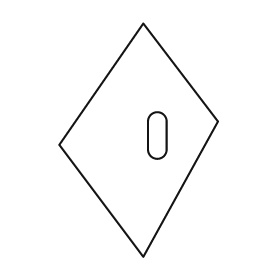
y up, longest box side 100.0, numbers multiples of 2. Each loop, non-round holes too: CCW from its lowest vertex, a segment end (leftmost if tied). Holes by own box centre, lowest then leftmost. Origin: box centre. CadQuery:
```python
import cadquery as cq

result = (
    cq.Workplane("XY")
    .moveTo(2.0, -50.0)
    .lineTo(34.0, 8.0)
    .lineTo(2.0, 50.0)
    .lineTo(-34.0, -2.0)
    .close()
    .moveTo(4.0, -4.0)
    .threePointArc((8.0, -8.0), (12.0, -4.0))
    .lineTo(12.0, 8.0)
    .threePointArc((8.0, 12.0), (4.0, 8.0))
    .close()
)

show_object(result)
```